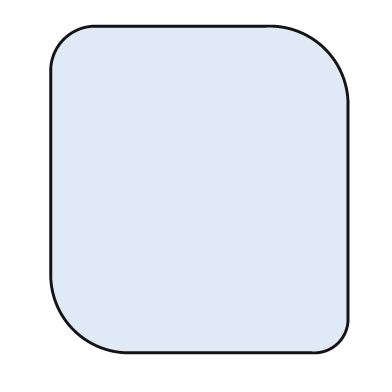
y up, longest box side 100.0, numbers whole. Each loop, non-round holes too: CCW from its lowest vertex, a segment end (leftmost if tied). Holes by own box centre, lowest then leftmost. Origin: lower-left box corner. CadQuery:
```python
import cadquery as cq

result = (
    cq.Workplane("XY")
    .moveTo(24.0, 0.0)
    .lineTo(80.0, 0.0)
    .threePointArc((88.0, 3.0), (91.0, 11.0))
    .lineTo(91.0, 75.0)
    .threePointArc((84.0, 93.0), (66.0, 100.0))
    .lineTo(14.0, 100.0)
    .threePointArc((4.0, 96.0), (0.0, 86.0))
    .lineTo(0.0, 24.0)
    .threePointArc((7.0, 7.0), (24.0, 0.0))
    .close()
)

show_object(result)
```